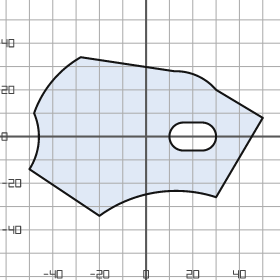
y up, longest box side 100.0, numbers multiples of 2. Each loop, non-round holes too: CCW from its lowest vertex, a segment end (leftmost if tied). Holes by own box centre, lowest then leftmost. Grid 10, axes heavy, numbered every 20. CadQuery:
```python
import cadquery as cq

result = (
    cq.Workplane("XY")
    .moveTo(-20.0, -34.0)
    .threePointArc((4.0, -24.0), (30.0, -26.0))
    .lineTo(50.0, 8.0)
    .lineTo(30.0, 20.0)
    .threePointArc((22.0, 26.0), (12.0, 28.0))
    .lineTo(-28.0, 34.0)
    .threePointArc((-40.0, 24.0), (-48.0, 10.0))
    .threePointArc((-46.0, -2.0), (-50.0, -14.0))
    .close()
    .moveTo(16.0, -6.0)
    .lineTo(24.0, -6.0)
    .threePointArc((30.0, 0.0), (24.0, 6.0))
    .lineTo(16.0, 6.0)
    .threePointArc((10.0, 0.0), (16.0, -6.0))
    .close()
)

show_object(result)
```